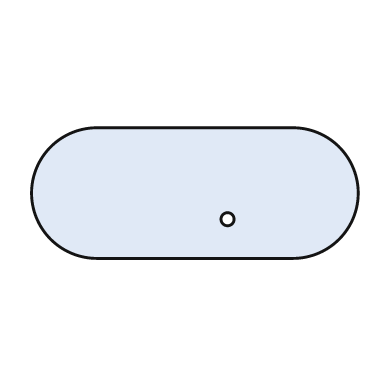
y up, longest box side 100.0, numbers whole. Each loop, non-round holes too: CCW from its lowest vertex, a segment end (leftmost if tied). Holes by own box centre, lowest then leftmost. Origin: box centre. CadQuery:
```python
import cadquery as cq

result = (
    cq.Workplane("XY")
    .moveTo(-30.0, -20.0)
    .lineTo(30.0, -20.0)
    .threePointArc((50.0, 0.0), (30.0, 20.0))
    .lineTo(-30.0, 20.0)
    .threePointArc((-50.0, 0.0), (-30.0, -20.0))
    .close()
    .moveTo(10.0, -8.0)
    .circle(2.0)
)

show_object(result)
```